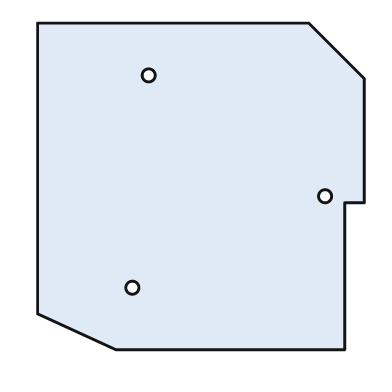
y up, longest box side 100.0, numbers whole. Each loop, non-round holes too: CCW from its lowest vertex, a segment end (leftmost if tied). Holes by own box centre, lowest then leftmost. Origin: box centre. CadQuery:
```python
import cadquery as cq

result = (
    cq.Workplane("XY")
    .moveTo(-26.0, -50.0)
    .lineTo(44.0, -50.0)
    .lineTo(44.0, -5.0)
    .lineTo(50.0, -5.0)
    .lineTo(50.0, 33.0)
    .lineTo(33.0, 50.0)
    .lineTo(-50.0, 50.0)
    .lineTo(-50.0, -39.0)
    .close()
    .moveTo(-21.0, -31.0)
    .circle(2.0)
    .moveTo(38.0, -3.0)
    .circle(2.0)
    .moveTo(-16.0, 34.0)
    .circle(2.0)
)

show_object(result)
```